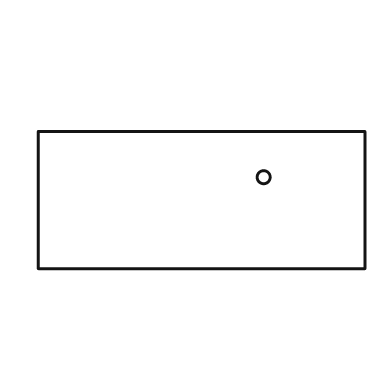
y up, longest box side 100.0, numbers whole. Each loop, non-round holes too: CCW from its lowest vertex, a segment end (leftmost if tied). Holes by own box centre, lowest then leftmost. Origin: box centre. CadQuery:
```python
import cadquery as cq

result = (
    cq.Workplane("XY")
    .moveTo(-50.0, -21.0)
    .lineTo(50.0, -21.0)
    .lineTo(50.0, 21.0)
    .lineTo(-50.0, 21.0)
    .close()
    .moveTo(19.0, 7.0)
    .circle(2.0)
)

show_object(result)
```